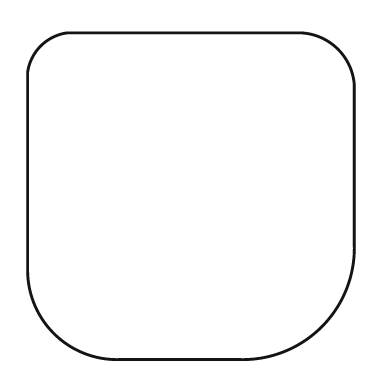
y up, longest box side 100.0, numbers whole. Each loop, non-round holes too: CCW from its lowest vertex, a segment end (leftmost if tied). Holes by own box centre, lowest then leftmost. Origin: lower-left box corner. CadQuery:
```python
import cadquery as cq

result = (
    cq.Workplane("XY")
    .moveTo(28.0, 0.0)
    .lineTo(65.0, 0.0)
    .threePointArc((90.0, 10.0), (100.0, 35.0))
    .lineTo(100.0, 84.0)
    .threePointArc((95.0, 95.0), (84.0, 100.0))
    .lineTo(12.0, 100.0)
    .threePointArc((4.0, 96.0), (0.0, 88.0))
    .lineTo(0.0, 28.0)
    .threePointArc((8.0, 8.0), (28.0, 0.0))
    .close()
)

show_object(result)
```